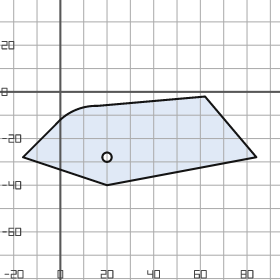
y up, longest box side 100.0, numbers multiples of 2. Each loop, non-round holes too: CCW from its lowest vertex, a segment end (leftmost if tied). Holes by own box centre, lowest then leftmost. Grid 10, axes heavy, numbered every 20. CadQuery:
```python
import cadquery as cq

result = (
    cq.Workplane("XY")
    .moveTo(20.0, -40.0)
    .lineTo(84.0, -28.0)
    .lineTo(62.0, -2.0)
    .lineTo(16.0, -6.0)
    .threePointArc((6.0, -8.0), (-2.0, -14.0))
    .lineTo(-16.0, -28.0)
    .close()
    .moveTo(20.0, -28.0)
    .circle(2.0)
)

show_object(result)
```